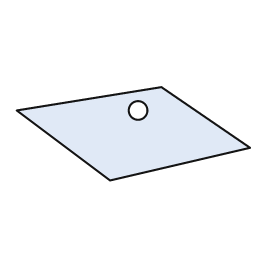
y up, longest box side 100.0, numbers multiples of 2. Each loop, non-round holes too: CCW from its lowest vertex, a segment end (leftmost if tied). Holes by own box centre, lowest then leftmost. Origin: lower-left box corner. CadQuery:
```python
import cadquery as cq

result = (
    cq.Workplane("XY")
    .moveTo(40.0, 0.0)
    .lineTo(100.0, 14.0)
    .lineTo(62.0, 40.0)
    .lineTo(0.0, 30.0)
    .close()
    .moveTo(52.0, 30.0)
    .circle(4.0)
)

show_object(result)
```